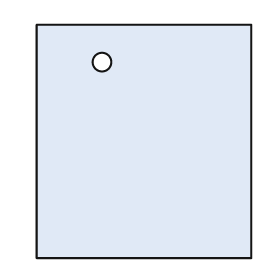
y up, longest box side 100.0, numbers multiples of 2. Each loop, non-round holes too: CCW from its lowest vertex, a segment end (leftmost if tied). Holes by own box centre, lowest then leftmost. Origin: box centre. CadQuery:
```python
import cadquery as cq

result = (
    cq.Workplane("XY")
    .moveTo(-46.0, -50.0)
    .lineTo(46.0, -50.0)
    .lineTo(46.0, 50.0)
    .lineTo(-46.0, 50.0)
    .close()
    .moveTo(-18.0, 34.0)
    .circle(4.0)
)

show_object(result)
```